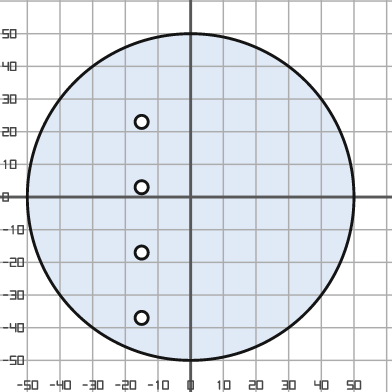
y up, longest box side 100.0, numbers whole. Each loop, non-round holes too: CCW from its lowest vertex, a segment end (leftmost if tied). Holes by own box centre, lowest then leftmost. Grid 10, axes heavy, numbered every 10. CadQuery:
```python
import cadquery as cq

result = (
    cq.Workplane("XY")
    .moveTo(0.0, 0.0)
    .circle(50.0)
    .moveTo(-15.0, -37.0)
    .circle(2.0)
    .moveTo(-15.0, -17.0)
    .circle(2.0)
    .moveTo(-15.0, 3.0)
    .circle(2.0)
    .moveTo(-15.0, 23.0)
    .circle(2.0)
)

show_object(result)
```